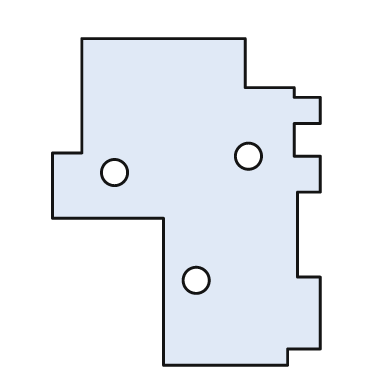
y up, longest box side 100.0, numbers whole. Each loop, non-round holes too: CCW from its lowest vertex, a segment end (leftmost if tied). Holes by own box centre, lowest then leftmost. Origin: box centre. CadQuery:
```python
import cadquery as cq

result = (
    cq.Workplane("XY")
    .moveTo(-7.0, -50.0)
    .lineTo(31.0, -50.0)
    .lineTo(31.0, -45.0)
    .lineTo(41.0, -45.0)
    .lineTo(41.0, -23.0)
    .lineTo(34.0, -23.0)
    .lineTo(34.0, 3.0)
    .lineTo(41.0, 3.0)
    .lineTo(41.0, 14.0)
    .lineTo(33.0, 14.0)
    .lineTo(33.0, 24.0)
    .lineTo(41.0, 24.0)
    .lineTo(41.0, 32.0)
    .lineTo(33.0, 32.0)
    .lineTo(33.0, 35.0)
    .lineTo(18.0, 35.0)
    .lineTo(18.0, 50.0)
    .lineTo(-32.0, 50.0)
    .lineTo(-32.0, 15.0)
    .lineTo(-41.0, 15.0)
    .lineTo(-41.0, -5.0)
    .lineTo(-7.0, -5.0)
    .close()
    .moveTo(3.0, -24.0)
    .circle(4.0)
    .moveTo(-22.0, 9.0)
    .circle(4.0)
    .moveTo(19.0, 14.0)
    .circle(4.0)
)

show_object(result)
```